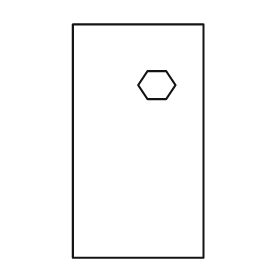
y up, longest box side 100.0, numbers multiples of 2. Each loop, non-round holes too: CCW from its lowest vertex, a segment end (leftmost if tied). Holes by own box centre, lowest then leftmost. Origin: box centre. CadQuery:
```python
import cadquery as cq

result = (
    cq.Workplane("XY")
    .moveTo(-28.0, -50.0)
    .lineTo(28.0, -50.0)
    .lineTo(28.0, 50.0)
    .lineTo(-28.0, 50.0)
    .close()
    .moveTo(4.0, 18.0)
    .lineTo(12.0, 18.0)
    .lineTo(16.0, 24.0)
    .lineTo(12.0, 30.0)
    .lineTo(4.0, 30.0)
    .lineTo(0.0, 24.0)
    .close()
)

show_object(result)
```